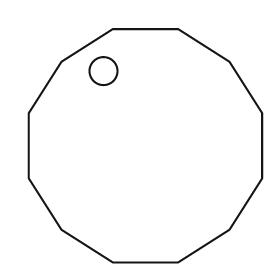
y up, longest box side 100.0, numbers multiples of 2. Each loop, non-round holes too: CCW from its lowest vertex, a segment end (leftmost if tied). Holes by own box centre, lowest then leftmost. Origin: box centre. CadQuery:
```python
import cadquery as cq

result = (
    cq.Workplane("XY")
    .moveTo(-14.0, -50.0)
    .lineTo(14.0, -50.0)
    .lineTo(36.0, -36.0)
    .lineTo(50.0, -14.0)
    .lineTo(50.0, 14.0)
    .lineTo(36.0, 36.0)
    .lineTo(14.0, 50.0)
    .lineTo(-14.0, 50.0)
    .lineTo(-36.0, 36.0)
    .lineTo(-50.0, 14.0)
    .lineTo(-50.0, -14.0)
    .lineTo(-36.0, -36.0)
    .close()
    .moveTo(-18.0, 32.0)
    .circle(6.0)
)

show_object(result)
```